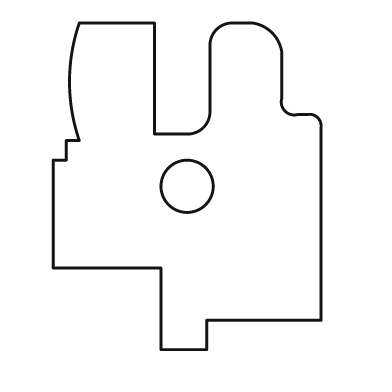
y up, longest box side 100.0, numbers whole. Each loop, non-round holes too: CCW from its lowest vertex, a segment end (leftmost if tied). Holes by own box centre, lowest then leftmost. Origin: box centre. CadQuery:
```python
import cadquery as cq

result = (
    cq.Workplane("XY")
    .moveTo(-8.0, -50.0)
    .lineTo(6.0, -50.0)
    .lineTo(6.0, -41.0)
    .lineTo(41.0, -41.0)
    .lineTo(41.0, 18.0)
    .threePointArc((40.0, 21.0), (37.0, 22.0))
    .lineTo(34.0, 22.0)
    .threePointArc((30.0, 23.0), (29.0, 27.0))
    .lineTo(29.0, 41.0)
    .threePointArc((26.0, 47.0), (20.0, 50.0))
    .lineTo(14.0, 50.0)
    .threePointArc((9.0, 48.0), (7.0, 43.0))
    .lineTo(7.0, 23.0)
    .threePointArc((5.0, 18.0), (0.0, 16.0))
    .lineTo(-10.0, 16.0)
    .lineTo(-10.0, 50.0)
    .lineTo(-33.0, 50.0)
    .threePointArc((-36.0, 32.0), (-33.0, 14.0))
    .lineTo(-37.0, 14.0)
    .lineTo(-37.0, 8.0)
    .lineTo(-41.0, 8.0)
    .lineTo(-41.0, -25.0)
    .lineTo(-8.0, -25.0)
    .close()
    .moveTo(0.0, 0.0)
    .circle(8.0)
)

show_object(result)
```